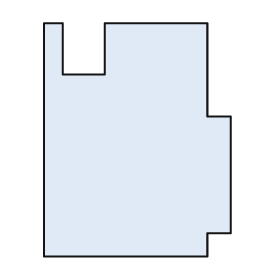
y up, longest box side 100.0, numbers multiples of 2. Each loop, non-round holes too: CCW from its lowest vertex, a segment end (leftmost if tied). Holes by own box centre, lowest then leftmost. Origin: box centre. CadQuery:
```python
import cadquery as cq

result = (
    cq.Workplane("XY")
    .moveTo(-40.0, -50.0)
    .lineTo(30.0, -50.0)
    .lineTo(30.0, -40.0)
    .lineTo(40.0, -40.0)
    .lineTo(40.0, 10.0)
    .lineTo(30.0, 10.0)
    .lineTo(30.0, 50.0)
    .lineTo(-14.0, 50.0)
    .lineTo(-14.0, 28.0)
    .lineTo(-32.0, 28.0)
    .lineTo(-32.0, 50.0)
    .lineTo(-40.0, 50.0)
    .close()
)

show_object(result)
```